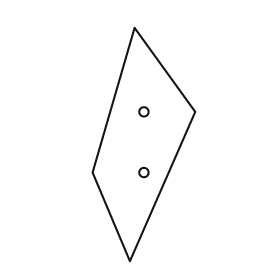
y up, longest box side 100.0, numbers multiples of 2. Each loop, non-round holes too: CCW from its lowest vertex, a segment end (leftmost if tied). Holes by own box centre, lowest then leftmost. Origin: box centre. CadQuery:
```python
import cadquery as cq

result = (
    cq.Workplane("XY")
    .moveTo(-6.0, -50.0)
    .lineTo(22.0, 14.0)
    .lineTo(-4.0, 50.0)
    .lineTo(-22.0, -12.0)
    .close()
    .moveTo(0.0, -12.0)
    .circle(2.0)
    .moveTo(0.0, 14.0)
    .circle(2.0)
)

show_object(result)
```